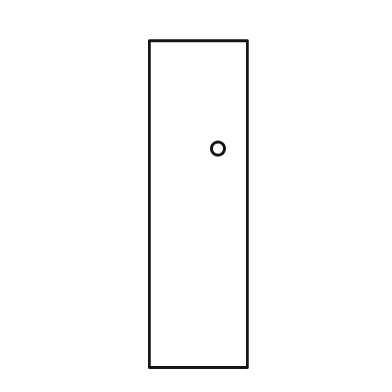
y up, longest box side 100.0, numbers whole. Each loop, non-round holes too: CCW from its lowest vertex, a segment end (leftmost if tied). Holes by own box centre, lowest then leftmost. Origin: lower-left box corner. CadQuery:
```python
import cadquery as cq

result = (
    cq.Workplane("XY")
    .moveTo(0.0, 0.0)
    .lineTo(30.0, 0.0)
    .lineTo(30.0, 100.0)
    .lineTo(0.0, 100.0)
    .close()
    .moveTo(21.0, 67.0)
    .circle(2.0)
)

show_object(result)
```